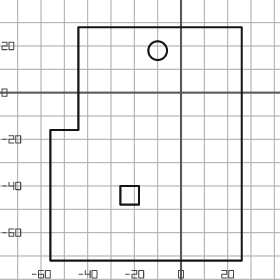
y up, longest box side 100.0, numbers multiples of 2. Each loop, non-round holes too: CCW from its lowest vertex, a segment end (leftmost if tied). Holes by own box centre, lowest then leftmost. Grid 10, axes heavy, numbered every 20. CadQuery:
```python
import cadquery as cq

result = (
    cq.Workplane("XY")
    .moveTo(-56.0, -72.0)
    .lineTo(26.0, -72.0)
    .lineTo(26.0, 28.0)
    .lineTo(-44.0, 28.0)
    .lineTo(-44.0, -16.0)
    .lineTo(-56.0, -16.0)
    .close()
    .moveTo(-26.0, -48.0)
    .lineTo(-18.0, -48.0)
    .lineTo(-18.0, -40.0)
    .lineTo(-26.0, -40.0)
    .close()
    .moveTo(-10.0, 18.0)
    .circle(4.0)
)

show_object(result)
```